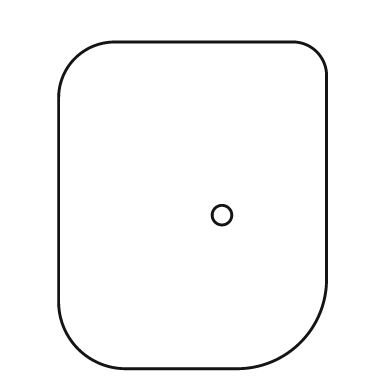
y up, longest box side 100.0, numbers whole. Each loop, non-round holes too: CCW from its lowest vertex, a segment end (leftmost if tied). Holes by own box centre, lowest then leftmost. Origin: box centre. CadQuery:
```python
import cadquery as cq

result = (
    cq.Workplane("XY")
    .moveTo(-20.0, -50.0)
    .lineTo(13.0, -50.0)
    .threePointArc((33.0, -42.0), (41.0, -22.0))
    .lineTo(41.0, 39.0)
    .threePointArc((38.0, 47.0), (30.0, 50.0))
    .lineTo(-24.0, 50.0)
    .threePointArc((-36.0, 45.0), (-41.0, 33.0))
    .lineTo(-41.0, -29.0)
    .threePointArc((-35.0, -44.0), (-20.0, -50.0))
    .close()
    .moveTo(9.0, -3.0)
    .circle(3.0)
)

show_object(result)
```